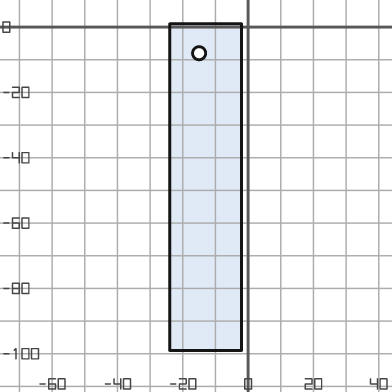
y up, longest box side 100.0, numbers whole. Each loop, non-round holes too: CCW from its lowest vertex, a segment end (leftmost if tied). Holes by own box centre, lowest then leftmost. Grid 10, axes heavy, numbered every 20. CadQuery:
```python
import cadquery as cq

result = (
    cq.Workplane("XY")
    .moveTo(-24.0, -99.0)
    .lineTo(-2.0, -99.0)
    .lineTo(-2.0, 1.0)
    .lineTo(-24.0, 1.0)
    .close()
    .moveTo(-15.0, -8.0)
    .circle(2.0)
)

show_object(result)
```